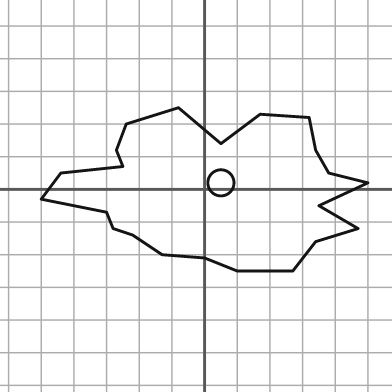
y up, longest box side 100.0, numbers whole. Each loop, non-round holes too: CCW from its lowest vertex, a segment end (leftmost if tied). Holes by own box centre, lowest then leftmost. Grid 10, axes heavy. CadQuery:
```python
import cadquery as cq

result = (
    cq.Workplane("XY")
    .moveTo(10.0, -25.0)
    .lineTo(27.0, -25.0)
    .lineTo(34.0, -16.0)
    .lineTo(47.0, -12.0)
    .lineTo(35.0, -5.0)
    .lineTo(50.0, 2.0)
    .lineTo(38.0, 5.0)
    .lineTo(34.0, 12.0)
    .lineTo(32.0, 22.0)
    .lineTo(17.0, 23.0)
    .lineTo(5.0, 14.0)
    .lineTo(-8.0, 25.0)
    .lineTo(-24.0, 20.0)
    .lineTo(-27.0, 12.0)
    .lineTo(-25.0, 7.0)
    .lineTo(-44.0, 5.0)
    .lineTo(-50.0, -3.0)
    .lineTo(-30.0, -7.0)
    .lineTo(-28.0, -12.0)
    .lineTo(-22.0, -14.0)
    .lineTo(-13.0, -20.0)
    .lineTo(0.0, -21.0)
    .close()
    .moveTo(5.0, 2.0)
    .circle(4.0)
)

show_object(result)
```